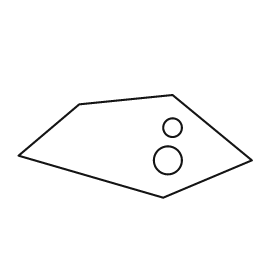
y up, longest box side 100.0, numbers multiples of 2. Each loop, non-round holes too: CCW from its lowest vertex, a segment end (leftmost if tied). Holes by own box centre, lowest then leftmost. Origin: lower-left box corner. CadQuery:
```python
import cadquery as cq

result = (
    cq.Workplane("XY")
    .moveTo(62.0, 0.0)
    .lineTo(100.0, 16.0)
    .lineTo(66.0, 44.0)
    .lineTo(26.0, 40.0)
    .lineTo(0.0, 18.0)
    .close()
    .moveTo(64.0, 16.0)
    .circle(6.0)
    .moveTo(66.0, 30.0)
    .circle(4.0)
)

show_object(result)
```